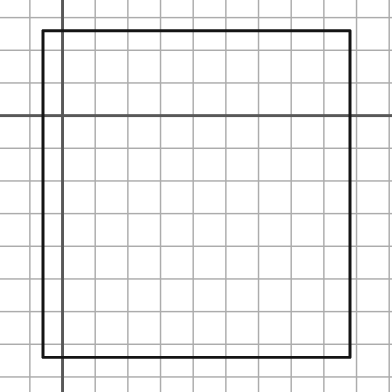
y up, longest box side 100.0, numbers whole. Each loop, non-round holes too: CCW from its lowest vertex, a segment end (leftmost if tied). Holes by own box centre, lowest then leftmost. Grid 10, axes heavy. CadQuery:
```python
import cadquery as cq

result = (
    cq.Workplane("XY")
    .moveTo(-6.0, -74.0)
    .lineTo(88.0, -74.0)
    .lineTo(88.0, 26.0)
    .lineTo(-6.0, 26.0)
    .close()
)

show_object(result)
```